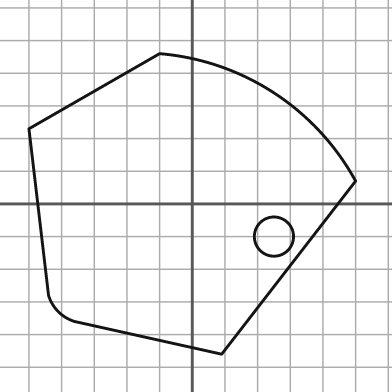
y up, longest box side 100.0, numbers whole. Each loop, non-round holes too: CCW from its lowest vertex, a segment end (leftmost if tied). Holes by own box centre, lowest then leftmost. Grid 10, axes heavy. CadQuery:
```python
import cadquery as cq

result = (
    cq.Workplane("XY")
    .moveTo(9.0, -46.0)
    .lineTo(50.0, 7.0)
    .threePointArc((25.0, 34.0), (-10.0, 46.0))
    .lineTo(-50.0, 23.0)
    .lineTo(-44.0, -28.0)
    .threePointArc((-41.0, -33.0), (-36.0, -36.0))
    .close()
    .moveTo(25.0, -10.0)
    .circle(6.0)
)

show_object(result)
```